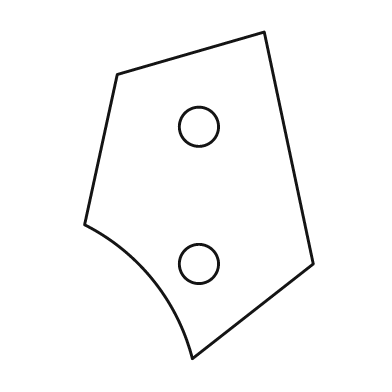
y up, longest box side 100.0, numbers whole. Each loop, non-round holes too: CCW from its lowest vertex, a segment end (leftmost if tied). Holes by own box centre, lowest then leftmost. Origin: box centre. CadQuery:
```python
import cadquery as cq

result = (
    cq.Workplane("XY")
    .moveTo(-2.0, -50.0)
    .lineTo(35.0, -21.0)
    .lineTo(20.0, 50.0)
    .lineTo(-25.0, 37.0)
    .lineTo(-35.0, -9.0)
    .threePointArc((-14.0, -26.0), (-2.0, -50.0))
    .close()
    .moveTo(0.0, -21.0)
    .circle(6.0)
    .moveTo(0.0, 21.0)
    .circle(6.0)
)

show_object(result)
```